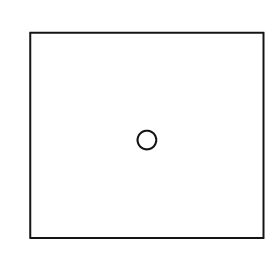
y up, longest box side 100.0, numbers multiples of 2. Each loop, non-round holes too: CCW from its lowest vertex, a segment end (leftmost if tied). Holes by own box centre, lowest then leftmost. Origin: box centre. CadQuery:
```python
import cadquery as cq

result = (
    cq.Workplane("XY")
    .moveTo(-50.0, -44.0)
    .lineTo(50.0, -44.0)
    .lineTo(50.0, 44.0)
    .lineTo(-50.0, 44.0)
    .close()
    .moveTo(0.0, -2.0)
    .circle(4.0)
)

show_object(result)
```